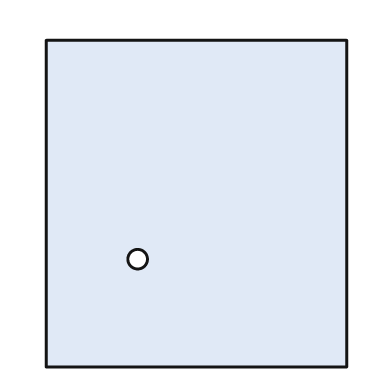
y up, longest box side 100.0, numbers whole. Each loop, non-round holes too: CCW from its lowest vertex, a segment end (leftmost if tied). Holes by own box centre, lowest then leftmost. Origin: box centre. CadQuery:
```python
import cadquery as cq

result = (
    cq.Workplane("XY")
    .moveTo(-46.0, -50.0)
    .lineTo(46.0, -50.0)
    .lineTo(46.0, 50.0)
    .lineTo(-46.0, 50.0)
    .close()
    .moveTo(-18.0, -17.0)
    .circle(3.0)
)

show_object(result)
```